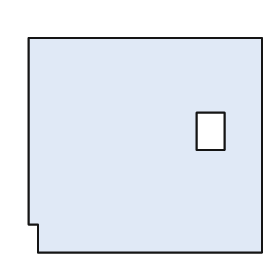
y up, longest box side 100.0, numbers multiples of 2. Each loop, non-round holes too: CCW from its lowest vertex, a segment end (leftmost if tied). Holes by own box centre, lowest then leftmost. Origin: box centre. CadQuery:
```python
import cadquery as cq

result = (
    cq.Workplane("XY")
    .moveTo(-46.0, -46.0)
    .lineTo(50.0, -46.0)
    .lineTo(50.0, 46.0)
    .lineTo(-50.0, 46.0)
    .lineTo(-50.0, -34.0)
    .lineTo(-46.0, -34.0)
    .close()
    .moveTo(22.0, -2.0)
    .lineTo(34.0, -2.0)
    .lineTo(34.0, 14.0)
    .lineTo(22.0, 14.0)
    .close()
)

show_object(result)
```